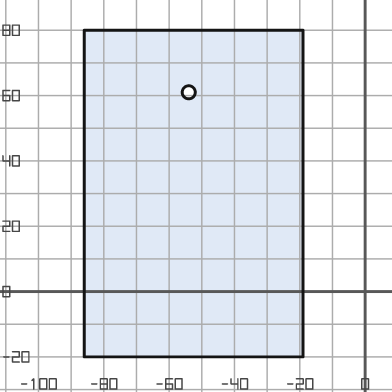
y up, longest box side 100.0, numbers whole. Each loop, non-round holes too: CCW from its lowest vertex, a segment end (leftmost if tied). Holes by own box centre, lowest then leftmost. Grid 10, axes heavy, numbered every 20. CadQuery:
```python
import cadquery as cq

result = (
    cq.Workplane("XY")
    .moveTo(-86.0, -20.0)
    .lineTo(-19.0, -20.0)
    .lineTo(-19.0, 80.0)
    .lineTo(-86.0, 80.0)
    .close()
    .moveTo(-54.0, 61.0)
    .circle(2.0)
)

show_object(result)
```